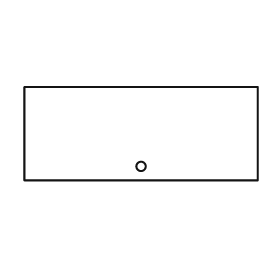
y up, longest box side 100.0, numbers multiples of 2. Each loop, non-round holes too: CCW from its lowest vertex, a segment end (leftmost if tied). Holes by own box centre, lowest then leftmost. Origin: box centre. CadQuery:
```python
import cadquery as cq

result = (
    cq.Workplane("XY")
    .moveTo(-50.0, -20.0)
    .lineTo(50.0, -20.0)
    .lineTo(50.0, 20.0)
    .lineTo(-50.0, 20.0)
    .close()
    .moveTo(0.0, -14.0)
    .circle(2.0)
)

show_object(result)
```